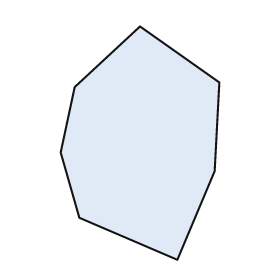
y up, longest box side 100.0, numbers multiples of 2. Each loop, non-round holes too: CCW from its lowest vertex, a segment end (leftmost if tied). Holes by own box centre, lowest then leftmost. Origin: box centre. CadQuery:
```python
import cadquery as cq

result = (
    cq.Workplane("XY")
    .moveTo(16.0, -50.0)
    .lineTo(32.0, -12.0)
    .lineTo(34.0, 26.0)
    .lineTo(0.0, 50.0)
    .lineTo(-28.0, 24.0)
    .lineTo(-34.0, -4.0)
    .lineTo(-26.0, -32.0)
    .close()
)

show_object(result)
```